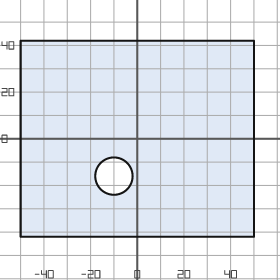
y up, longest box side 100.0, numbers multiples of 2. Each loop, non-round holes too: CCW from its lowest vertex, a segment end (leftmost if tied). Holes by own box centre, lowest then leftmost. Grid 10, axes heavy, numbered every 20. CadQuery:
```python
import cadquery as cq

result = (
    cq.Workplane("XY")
    .moveTo(-50.0, -42.0)
    .lineTo(50.0, -42.0)
    .lineTo(50.0, 42.0)
    .lineTo(-50.0, 42.0)
    .close()
    .moveTo(-10.0, -16.0)
    .circle(8.0)
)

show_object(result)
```